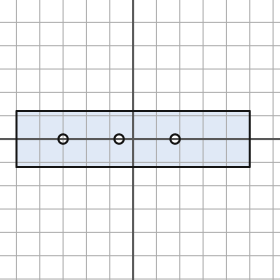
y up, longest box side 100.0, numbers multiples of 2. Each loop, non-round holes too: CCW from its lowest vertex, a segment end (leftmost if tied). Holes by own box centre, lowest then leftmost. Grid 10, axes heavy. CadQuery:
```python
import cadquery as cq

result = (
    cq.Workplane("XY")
    .moveTo(-50.0, -12.0)
    .lineTo(50.0, -12.0)
    .lineTo(50.0, 12.0)
    .lineTo(-50.0, 12.0)
    .close()
    .moveTo(-30.0, 0.0)
    .circle(2.0)
    .moveTo(-6.0, 0.0)
    .circle(2.0)
    .moveTo(18.0, 0.0)
    .circle(2.0)
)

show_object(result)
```